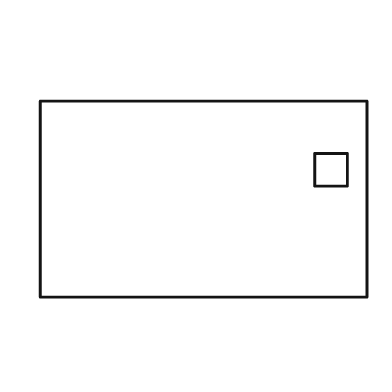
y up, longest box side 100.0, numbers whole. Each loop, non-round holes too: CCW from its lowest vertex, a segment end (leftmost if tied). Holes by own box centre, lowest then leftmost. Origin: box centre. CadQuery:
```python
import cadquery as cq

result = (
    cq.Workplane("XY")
    .moveTo(-50.0, -30.0)
    .lineTo(50.0, -30.0)
    .lineTo(50.0, 30.0)
    .lineTo(-50.0, 30.0)
    .close()
    .moveTo(34.0, 4.0)
    .lineTo(44.0, 4.0)
    .lineTo(44.0, 14.0)
    .lineTo(34.0, 14.0)
    .close()
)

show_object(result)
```